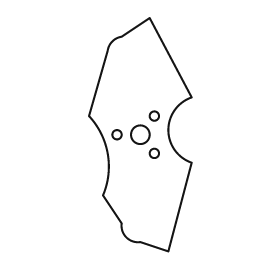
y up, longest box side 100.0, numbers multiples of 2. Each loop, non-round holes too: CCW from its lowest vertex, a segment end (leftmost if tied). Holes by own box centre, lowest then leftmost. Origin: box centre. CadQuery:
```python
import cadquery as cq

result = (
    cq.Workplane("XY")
    .moveTo(12.0, -50.0)
    .lineTo(22.0, -12.0)
    .threePointArc((12.0, 2.0), (22.0, 16.0))
    .lineTo(4.0, 50.0)
    .lineTo(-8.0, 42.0)
    .threePointArc((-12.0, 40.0), (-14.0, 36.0))
    .lineTo(-22.0, 8.0)
    .threePointArc((-14.0, -8.0), (-16.0, -26.0))
    .lineTo(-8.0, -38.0)
    .threePointArc((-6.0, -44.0), (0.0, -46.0))
    .close()
    .moveTo(6.0, -8.0)
    .circle(2.0)
    .moveTo(-10.0, 0.0)
    .circle(2.0)
    .moveTo(0.0, 0.0)
    .circle(4.0)
    .moveTo(6.0, 8.0)
    .circle(2.0)
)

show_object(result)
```